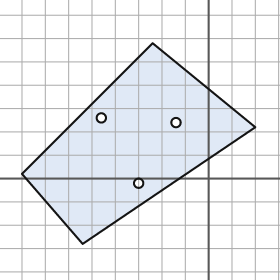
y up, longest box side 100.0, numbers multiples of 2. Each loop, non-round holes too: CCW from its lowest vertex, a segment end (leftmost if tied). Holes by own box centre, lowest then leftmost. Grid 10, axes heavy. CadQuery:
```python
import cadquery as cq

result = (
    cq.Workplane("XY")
    .moveTo(-54.0, -28.0)
    .lineTo(20.0, 22.0)
    .lineTo(-24.0, 58.0)
    .lineTo(-80.0, 2.0)
    .close()
    .moveTo(-30.0, -2.0)
    .circle(2.0)
    .moveTo(-14.0, 24.0)
    .circle(2.0)
    .moveTo(-46.0, 26.0)
    .circle(2.0)
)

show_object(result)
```